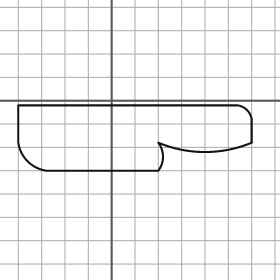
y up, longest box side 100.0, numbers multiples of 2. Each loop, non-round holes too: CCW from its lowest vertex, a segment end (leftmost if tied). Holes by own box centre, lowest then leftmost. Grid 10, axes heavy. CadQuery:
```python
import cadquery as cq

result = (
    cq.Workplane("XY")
    .moveTo(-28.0, -30.0)
    .lineTo(20.0, -30.0)
    .threePointArc((22.0, -24.0), (20.0, -18.0))
    .threePointArc((40.0, -22.0), (60.0, -18.0))
    .lineTo(60.0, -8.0)
    .threePointArc((58.0, -4.0), (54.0, -2.0))
    .lineTo(-40.0, -2.0)
    .lineTo(-40.0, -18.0)
    .threePointArc((-36.0, -26.0), (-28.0, -30.0))
    .close()
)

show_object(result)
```